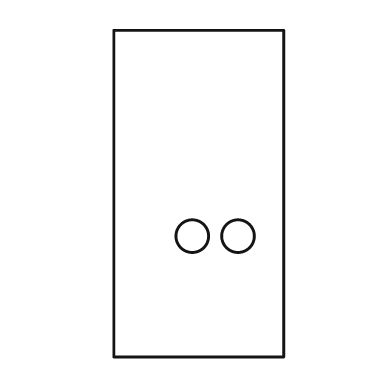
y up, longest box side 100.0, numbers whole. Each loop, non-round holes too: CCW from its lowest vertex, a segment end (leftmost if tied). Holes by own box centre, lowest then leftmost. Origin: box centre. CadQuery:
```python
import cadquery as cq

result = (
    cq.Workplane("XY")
    .moveTo(-26.0, -50.0)
    .lineTo(26.0, -50.0)
    .lineTo(26.0, 50.0)
    .lineTo(-26.0, 50.0)
    .close()
    .moveTo(-2.0, -13.0)
    .circle(5.0)
    .moveTo(12.0, -13.0)
    .circle(5.0)
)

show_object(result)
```